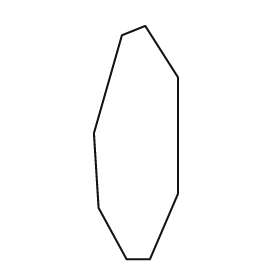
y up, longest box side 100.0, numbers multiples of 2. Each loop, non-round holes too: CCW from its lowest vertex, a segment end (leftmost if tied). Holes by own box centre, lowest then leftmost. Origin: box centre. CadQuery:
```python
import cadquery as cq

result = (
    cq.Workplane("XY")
    .moveTo(-4.0, -50.0)
    .lineTo(6.0, -50.0)
    .lineTo(18.0, -22.0)
    .lineTo(18.0, 28.0)
    .lineTo(4.0, 50.0)
    .lineTo(-6.0, 46.0)
    .lineTo(-18.0, 4.0)
    .lineTo(-16.0, -28.0)
    .close()
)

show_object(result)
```